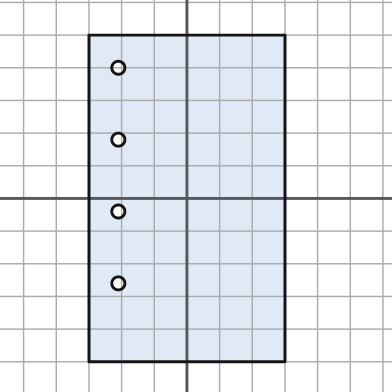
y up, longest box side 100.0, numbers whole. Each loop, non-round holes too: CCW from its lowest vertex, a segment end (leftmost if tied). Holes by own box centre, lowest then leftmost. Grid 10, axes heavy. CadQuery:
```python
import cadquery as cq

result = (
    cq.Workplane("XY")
    .moveTo(-30.0, -50.0)
    .lineTo(30.0, -50.0)
    .lineTo(30.0, 50.0)
    .lineTo(-30.0, 50.0)
    .close()
    .moveTo(-21.0, -26.0)
    .circle(2.0)
    .moveTo(-21.0, -4.0)
    .circle(2.0)
    .moveTo(-21.0, 18.0)
    .circle(2.0)
    .moveTo(-21.0, 40.0)
    .circle(2.0)
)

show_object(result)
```